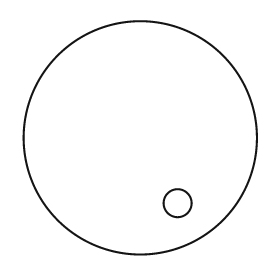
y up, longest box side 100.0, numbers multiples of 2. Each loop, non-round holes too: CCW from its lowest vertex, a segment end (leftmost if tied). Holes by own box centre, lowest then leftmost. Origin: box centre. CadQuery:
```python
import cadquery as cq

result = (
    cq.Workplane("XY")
    .moveTo(0.0, 0.0)
    .circle(50.0)
    .moveTo(16.0, -28.0)
    .circle(6.0)
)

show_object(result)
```